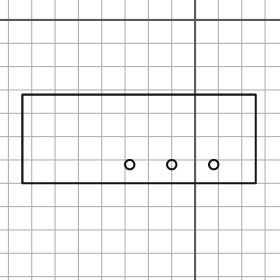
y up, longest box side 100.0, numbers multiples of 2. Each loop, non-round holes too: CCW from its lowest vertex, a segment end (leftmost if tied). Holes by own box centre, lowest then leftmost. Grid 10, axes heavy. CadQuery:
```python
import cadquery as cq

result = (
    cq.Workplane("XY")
    .moveTo(-74.0, -70.0)
    .lineTo(26.0, -70.0)
    .lineTo(26.0, -32.0)
    .lineTo(-74.0, -32.0)
    .close()
    .moveTo(-28.0, -62.0)
    .circle(2.0)
    .moveTo(-10.0, -62.0)
    .circle(2.0)
    .moveTo(8.0, -62.0)
    .circle(2.0)
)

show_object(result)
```